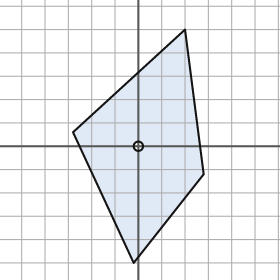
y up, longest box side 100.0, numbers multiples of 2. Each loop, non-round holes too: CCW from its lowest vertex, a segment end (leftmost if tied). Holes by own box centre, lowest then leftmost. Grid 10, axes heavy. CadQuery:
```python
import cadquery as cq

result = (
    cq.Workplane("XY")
    .moveTo(-2.0, -50.0)
    .lineTo(28.0, -12.0)
    .lineTo(20.0, 50.0)
    .lineTo(-28.0, 6.0)
    .close()
    .moveTo(0.0, 0.0)
    .circle(2.0)
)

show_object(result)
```